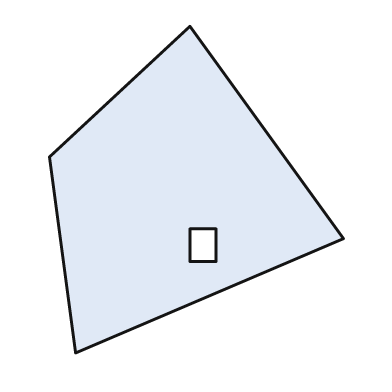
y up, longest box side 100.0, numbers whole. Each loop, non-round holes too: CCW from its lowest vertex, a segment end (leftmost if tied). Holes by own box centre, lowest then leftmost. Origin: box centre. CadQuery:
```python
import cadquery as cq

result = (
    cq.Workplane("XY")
    .moveTo(-37.0, -50.0)
    .lineTo(45.0, -15.0)
    .lineTo(-2.0, 50.0)
    .lineTo(-45.0, 10.0)
    .close()
    .moveTo(-2.0, -22.0)
    .lineTo(6.0, -22.0)
    .lineTo(6.0, -12.0)
    .lineTo(-2.0, -12.0)
    .close()
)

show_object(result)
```